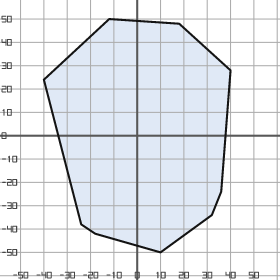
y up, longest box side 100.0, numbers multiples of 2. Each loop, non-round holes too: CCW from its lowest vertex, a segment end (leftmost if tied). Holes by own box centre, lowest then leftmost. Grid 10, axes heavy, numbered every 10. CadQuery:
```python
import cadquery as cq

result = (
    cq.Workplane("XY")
    .moveTo(10.0, -50.0)
    .lineTo(32.0, -34.0)
    .lineTo(36.0, -24.0)
    .lineTo(40.0, 28.0)
    .lineTo(18.0, 48.0)
    .lineTo(-12.0, 50.0)
    .lineTo(-40.0, 24.0)
    .lineTo(-24.0, -38.0)
    .lineTo(-18.0, -42.0)
    .close()
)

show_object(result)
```